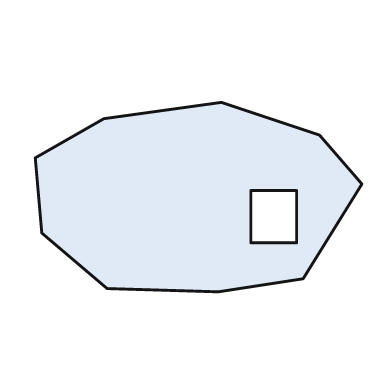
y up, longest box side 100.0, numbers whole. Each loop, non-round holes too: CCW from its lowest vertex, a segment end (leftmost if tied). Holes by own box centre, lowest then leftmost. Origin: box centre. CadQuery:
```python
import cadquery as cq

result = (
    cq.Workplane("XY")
    .moveTo(6.0, -29.0)
    .lineTo(32.0, -25.0)
    .lineTo(50.0, 4.0)
    .lineTo(37.0, 19.0)
    .lineTo(7.0, 29.0)
    .lineTo(-29.0, 24.0)
    .lineTo(-50.0, 12.0)
    .lineTo(-48.0, -11.0)
    .lineTo(-28.0, -28.0)
    .close()
    .moveTo(16.0, -14.0)
    .lineTo(30.0, -14.0)
    .lineTo(30.0, 2.0)
    .lineTo(16.0, 2.0)
    .close()
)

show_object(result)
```